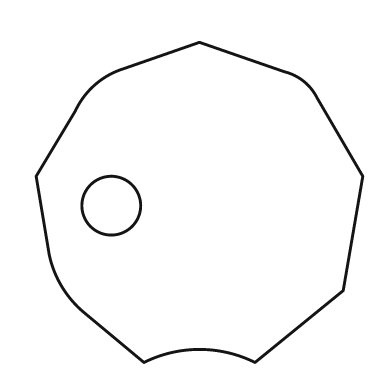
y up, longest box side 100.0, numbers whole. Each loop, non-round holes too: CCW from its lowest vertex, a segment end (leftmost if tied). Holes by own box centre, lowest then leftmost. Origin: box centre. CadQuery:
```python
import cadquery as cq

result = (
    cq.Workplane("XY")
    .moveTo(-17.0, -49.0)
    .threePointArc((0.0, -45.0), (17.0, -49.0))
    .lineTo(44.0, -27.0)
    .lineTo(50.0, 8.0)
    .lineTo(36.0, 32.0)
    .threePointArc((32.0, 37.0), (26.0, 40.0))
    .lineTo(0.0, 49.0)
    .lineTo(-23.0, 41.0)
    .threePointArc((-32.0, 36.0), (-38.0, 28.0))
    .lineTo(-50.0, 8.0)
    .lineTo(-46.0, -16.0)
    .threePointArc((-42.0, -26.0), (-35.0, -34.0))
    .close()
    .moveTo(-27.0, -1.0)
    .circle(9.0)
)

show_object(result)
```